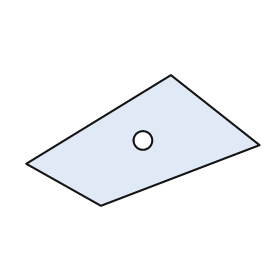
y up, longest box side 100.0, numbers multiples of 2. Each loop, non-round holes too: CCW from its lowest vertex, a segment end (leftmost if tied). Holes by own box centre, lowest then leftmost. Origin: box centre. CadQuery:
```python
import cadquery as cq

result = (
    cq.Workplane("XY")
    .moveTo(-18.0, -28.0)
    .lineTo(50.0, -2.0)
    .lineTo(12.0, 28.0)
    .lineTo(-50.0, -10.0)
    .close()
    .moveTo(0.0, 0.0)
    .circle(4.0)
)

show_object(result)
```